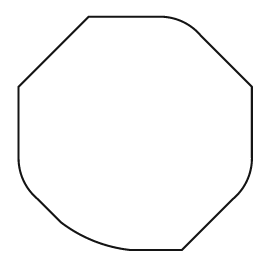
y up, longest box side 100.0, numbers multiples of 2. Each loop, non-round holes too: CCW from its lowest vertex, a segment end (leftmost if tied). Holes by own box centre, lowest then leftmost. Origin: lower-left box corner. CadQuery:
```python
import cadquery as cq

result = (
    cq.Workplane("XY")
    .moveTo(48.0, 0.0)
    .lineTo(70.0, 0.0)
    .lineTo(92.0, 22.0)
    .threePointArc((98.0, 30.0), (100.0, 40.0))
    .lineTo(100.0, 70.0)
    .lineTo(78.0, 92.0)
    .threePointArc((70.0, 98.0), (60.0, 100.0))
    .lineTo(30.0, 100.0)
    .lineTo(0.0, 70.0)
    .lineTo(0.0, 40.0)
    .threePointArc((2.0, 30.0), (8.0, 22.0))
    .lineTo(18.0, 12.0)
    .threePointArc((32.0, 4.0), (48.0, 0.0))
    .close()
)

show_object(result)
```